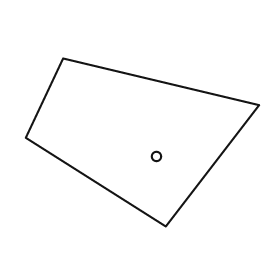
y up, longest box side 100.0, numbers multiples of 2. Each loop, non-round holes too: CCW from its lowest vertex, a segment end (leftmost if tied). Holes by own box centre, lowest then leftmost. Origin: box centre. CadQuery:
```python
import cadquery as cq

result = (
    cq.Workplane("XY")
    .moveTo(10.0, -36.0)
    .lineTo(50.0, 16.0)
    .lineTo(-34.0, 36.0)
    .lineTo(-50.0, 2.0)
    .close()
    .moveTo(6.0, -6.0)
    .circle(2.0)
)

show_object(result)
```